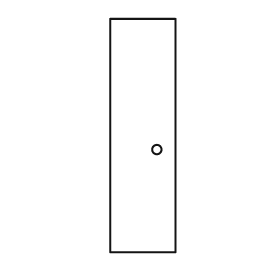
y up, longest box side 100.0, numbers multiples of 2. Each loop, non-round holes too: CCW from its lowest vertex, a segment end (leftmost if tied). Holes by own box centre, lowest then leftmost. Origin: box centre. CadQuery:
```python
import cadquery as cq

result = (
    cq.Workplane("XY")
    .moveTo(-14.0, -50.0)
    .lineTo(14.0, -50.0)
    .lineTo(14.0, 50.0)
    .lineTo(-14.0, 50.0)
    .close()
    .moveTo(6.0, -6.0)
    .circle(2.0)
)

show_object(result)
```